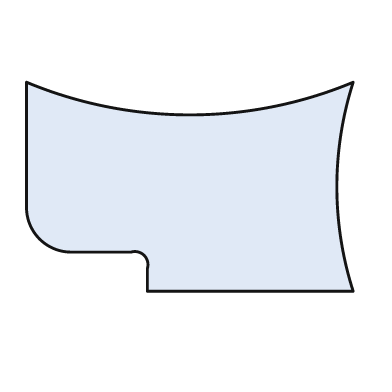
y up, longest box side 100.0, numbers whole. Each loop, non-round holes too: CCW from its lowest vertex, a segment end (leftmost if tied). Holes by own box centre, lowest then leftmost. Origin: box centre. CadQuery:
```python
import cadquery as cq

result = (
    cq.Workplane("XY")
    .moveTo(-13.0, -32.0)
    .lineTo(50.0, -32.0)
    .threePointArc((45.0, 0.0), (50.0, 32.0))
    .threePointArc((0.0, 22.0), (-50.0, 32.0))
    .lineTo(-50.0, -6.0)
    .threePointArc((-46.0, -16.0), (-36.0, -20.0))
    .lineTo(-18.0, -20.0)
    .threePointArc((-14.0, -21.0), (-13.0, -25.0))
    .close()
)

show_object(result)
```